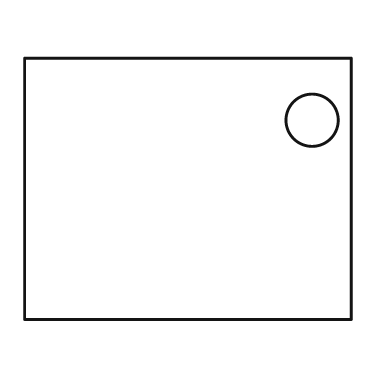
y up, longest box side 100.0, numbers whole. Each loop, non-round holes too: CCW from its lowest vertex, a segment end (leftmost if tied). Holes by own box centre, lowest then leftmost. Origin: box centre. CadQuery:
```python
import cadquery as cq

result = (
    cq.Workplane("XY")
    .moveTo(-50.0, -40.0)
    .lineTo(50.0, -40.0)
    .lineTo(50.0, 40.0)
    .lineTo(-50.0, 40.0)
    .close()
    .moveTo(38.0, 21.0)
    .circle(8.0)
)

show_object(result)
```